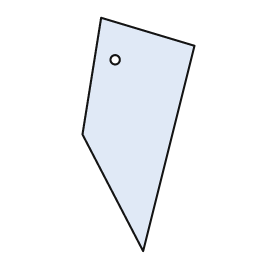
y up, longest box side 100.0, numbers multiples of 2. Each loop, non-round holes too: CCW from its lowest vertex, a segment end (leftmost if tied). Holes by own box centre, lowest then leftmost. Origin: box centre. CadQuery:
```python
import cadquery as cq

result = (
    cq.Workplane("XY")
    .moveTo(2.0, -50.0)
    .lineTo(24.0, 38.0)
    .lineTo(-16.0, 50.0)
    .lineTo(-24.0, 0.0)
    .close()
    .moveTo(-10.0, 32.0)
    .circle(2.0)
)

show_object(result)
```